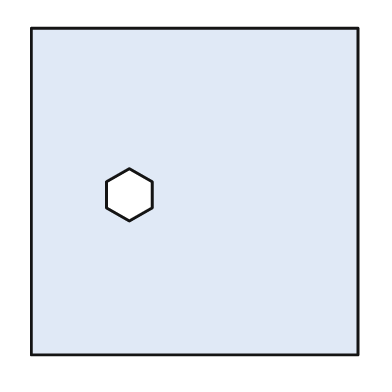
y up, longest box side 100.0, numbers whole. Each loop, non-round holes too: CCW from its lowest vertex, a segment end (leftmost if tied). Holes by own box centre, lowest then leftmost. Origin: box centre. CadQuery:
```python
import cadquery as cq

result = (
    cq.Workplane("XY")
    .moveTo(-50.0, -50.0)
    .lineTo(50.0, -50.0)
    .lineTo(50.0, 50.0)
    .lineTo(-50.0, 50.0)
    .close()
    .moveTo(-20.0, -9.0)
    .lineTo(-13.0, -5.0)
    .lineTo(-13.0, 3.0)
    .lineTo(-20.0, 7.0)
    .lineTo(-27.0, 3.0)
    .lineTo(-27.0, -5.0)
    .close()
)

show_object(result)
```